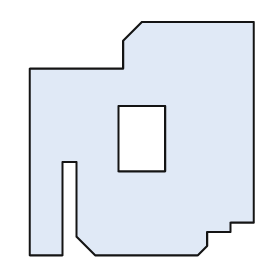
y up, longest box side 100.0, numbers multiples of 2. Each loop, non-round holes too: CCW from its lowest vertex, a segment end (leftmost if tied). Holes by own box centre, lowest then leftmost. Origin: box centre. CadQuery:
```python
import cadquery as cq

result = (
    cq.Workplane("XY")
    .moveTo(-48.0, -50.0)
    .lineTo(-34.0, -50.0)
    .lineTo(-34.0, -10.0)
    .lineTo(-28.0, -10.0)
    .lineTo(-28.0, -42.0)
    .lineTo(-20.0, -50.0)
    .lineTo(24.0, -50.0)
    .lineTo(28.0, -46.0)
    .lineTo(28.0, -40.0)
    .lineTo(38.0, -40.0)
    .lineTo(38.0, -36.0)
    .lineTo(48.0, -36.0)
    .lineTo(48.0, 50.0)
    .lineTo(0.0, 50.0)
    .lineTo(-8.0, 42.0)
    .lineTo(-8.0, 30.0)
    .lineTo(-48.0, 30.0)
    .close()
    .moveTo(-10.0, -14.0)
    .lineTo(10.0, -14.0)
    .lineTo(10.0, 14.0)
    .lineTo(-10.0, 14.0)
    .close()
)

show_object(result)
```